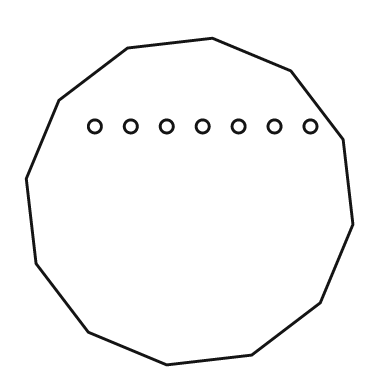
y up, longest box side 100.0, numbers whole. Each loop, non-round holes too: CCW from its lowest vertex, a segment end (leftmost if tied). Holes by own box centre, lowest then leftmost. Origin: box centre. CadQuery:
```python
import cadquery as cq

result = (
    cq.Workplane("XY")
    .moveTo(-7.0, -50.0)
    .lineTo(19.0, -47.0)
    .lineTo(40.0, -31.0)
    .lineTo(50.0, -7.0)
    .lineTo(47.0, 19.0)
    .lineTo(31.0, 40.0)
    .lineTo(7.0, 50.0)
    .lineTo(-19.0, 47.0)
    .lineTo(-40.0, 31.0)
    .lineTo(-50.0, 7.0)
    .lineTo(-47.0, -19.0)
    .lineTo(-31.0, -40.0)
    .close()
    .moveTo(-29.0, 23.0)
    .circle(2.0)
    .moveTo(-18.0, 23.0)
    .circle(2.0)
    .moveTo(-7.0, 23.0)
    .circle(2.0)
    .moveTo(4.0, 23.0)
    .circle(2.0)
    .moveTo(15.0, 23.0)
    .circle(2.0)
    .moveTo(26.0, 23.0)
    .circle(2.0)
    .moveTo(37.0, 23.0)
    .circle(2.0)
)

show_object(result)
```